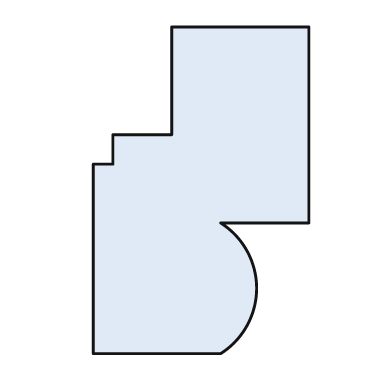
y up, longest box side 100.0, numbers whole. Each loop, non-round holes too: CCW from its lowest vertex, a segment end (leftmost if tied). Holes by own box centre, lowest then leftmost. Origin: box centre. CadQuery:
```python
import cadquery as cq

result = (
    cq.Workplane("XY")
    .moveTo(-33.0, -50.0)
    .lineTo(6.0, -50.0)
    .threePointArc((17.0, -30.0), (6.0, -10.0))
    .lineTo(33.0, -10.0)
    .lineTo(33.0, 50.0)
    .lineTo(-9.0, 50.0)
    .lineTo(-9.0, 17.0)
    .lineTo(-27.0, 17.0)
    .lineTo(-27.0, 8.0)
    .lineTo(-33.0, 8.0)
    .close()
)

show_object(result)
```